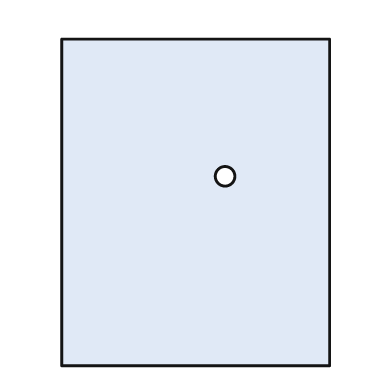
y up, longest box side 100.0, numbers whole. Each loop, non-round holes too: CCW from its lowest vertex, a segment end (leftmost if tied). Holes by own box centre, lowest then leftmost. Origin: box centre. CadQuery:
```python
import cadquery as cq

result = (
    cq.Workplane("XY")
    .moveTo(-41.0, -50.0)
    .lineTo(41.0, -50.0)
    .lineTo(41.0, 50.0)
    .lineTo(-41.0, 50.0)
    .close()
    .moveTo(9.0, 8.0)
    .circle(3.0)
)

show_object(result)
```